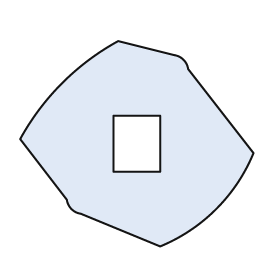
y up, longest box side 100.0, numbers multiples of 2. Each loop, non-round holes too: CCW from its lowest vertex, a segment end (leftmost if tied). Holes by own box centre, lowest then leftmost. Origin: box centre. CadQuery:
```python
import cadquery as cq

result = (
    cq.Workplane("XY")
    .moveTo(10.0, -44.0)
    .threePointArc((34.0, -28.0), (50.0, -4.0))
    .lineTo(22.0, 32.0)
    .threePointArc((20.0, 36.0), (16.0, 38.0))
    .lineTo(-8.0, 44.0)
    .threePointArc((-32.0, 26.0), (-50.0, 2.0))
    .lineTo(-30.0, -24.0)
    .threePointArc((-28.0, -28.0), (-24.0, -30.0))
    .close()
    .moveTo(-10.0, -12.0)
    .lineTo(10.0, -12.0)
    .lineTo(10.0, 12.0)
    .lineTo(-10.0, 12.0)
    .close()
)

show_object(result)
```